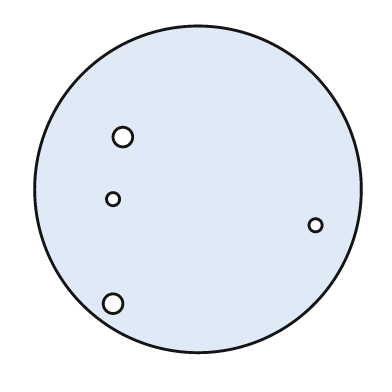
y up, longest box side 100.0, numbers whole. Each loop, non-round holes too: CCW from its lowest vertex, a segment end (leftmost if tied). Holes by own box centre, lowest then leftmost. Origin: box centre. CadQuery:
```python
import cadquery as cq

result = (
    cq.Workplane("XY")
    .moveTo(0.0, 0.0)
    .circle(50.0)
    .moveTo(-26.0, -35.0)
    .circle(3.0)
    .moveTo(36.0, -11.0)
    .circle(2.0)
    .moveTo(-26.0, -3.0)
    .circle(2.0)
    .moveTo(-23.0, 16.0)
    .circle(3.0)
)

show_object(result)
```